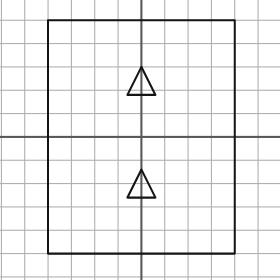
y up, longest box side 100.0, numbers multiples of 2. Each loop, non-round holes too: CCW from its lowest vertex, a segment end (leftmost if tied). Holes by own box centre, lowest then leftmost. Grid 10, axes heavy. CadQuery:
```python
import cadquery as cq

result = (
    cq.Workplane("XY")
    .moveTo(-40.0, -50.0)
    .lineTo(40.0, -50.0)
    .lineTo(40.0, 50.0)
    .lineTo(-40.0, 50.0)
    .close()
    .moveTo(-6.0, -26.0)
    .lineTo(6.0, -26.0)
    .lineTo(0.0, -14.0)
    .close()
    .moveTo(-6.0, 18.0)
    .lineTo(6.0, 18.0)
    .lineTo(0.0, 30.0)
    .close()
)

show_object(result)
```